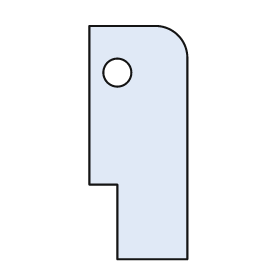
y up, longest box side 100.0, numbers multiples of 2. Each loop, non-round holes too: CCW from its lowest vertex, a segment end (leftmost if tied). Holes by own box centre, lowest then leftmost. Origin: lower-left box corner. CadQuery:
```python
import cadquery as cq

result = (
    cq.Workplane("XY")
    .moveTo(12.0, 0.0)
    .lineTo(42.0, 0.0)
    .lineTo(42.0, 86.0)
    .threePointArc((38.0, 96.0), (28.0, 100.0))
    .lineTo(0.0, 100.0)
    .lineTo(0.0, 32.0)
    .lineTo(12.0, 32.0)
    .close()
    .moveTo(12.0, 80.0)
    .circle(6.0)
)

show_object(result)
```